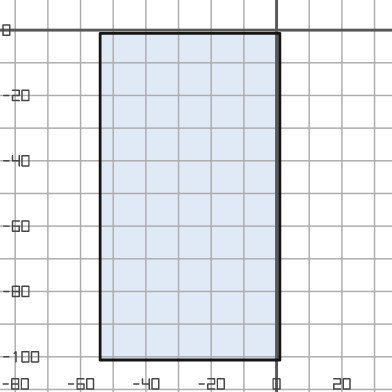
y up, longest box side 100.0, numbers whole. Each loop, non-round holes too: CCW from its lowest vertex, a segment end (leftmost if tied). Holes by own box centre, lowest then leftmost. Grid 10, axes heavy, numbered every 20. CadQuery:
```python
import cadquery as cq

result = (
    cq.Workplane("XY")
    .moveTo(-54.0, -101.0)
    .lineTo(1.0, -101.0)
    .lineTo(1.0, -1.0)
    .lineTo(-54.0, -1.0)
    .close()
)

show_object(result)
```